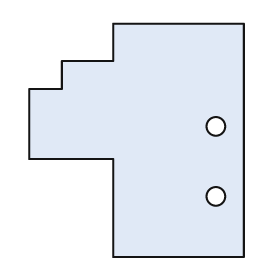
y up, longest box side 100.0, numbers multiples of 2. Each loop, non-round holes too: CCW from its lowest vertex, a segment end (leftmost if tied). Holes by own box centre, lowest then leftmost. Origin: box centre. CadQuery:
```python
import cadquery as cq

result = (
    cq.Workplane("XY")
    .moveTo(-10.0, -50.0)
    .lineTo(46.0, -50.0)
    .lineTo(46.0, 50.0)
    .lineTo(-10.0, 50.0)
    .lineTo(-10.0, 34.0)
    .lineTo(-32.0, 34.0)
    .lineTo(-32.0, 22.0)
    .lineTo(-46.0, 22.0)
    .lineTo(-46.0, -8.0)
    .lineTo(-10.0, -8.0)
    .close()
    .moveTo(34.0, -24.0)
    .circle(4.0)
    .moveTo(34.0, 6.0)
    .circle(4.0)
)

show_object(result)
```